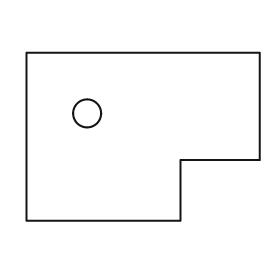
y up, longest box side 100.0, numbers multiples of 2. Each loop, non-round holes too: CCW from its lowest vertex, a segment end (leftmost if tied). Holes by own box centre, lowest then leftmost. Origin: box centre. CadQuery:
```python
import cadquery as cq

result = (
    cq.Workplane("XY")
    .moveTo(-50.0, -36.0)
    .lineTo(16.0, -36.0)
    .lineTo(16.0, -10.0)
    .lineTo(50.0, -10.0)
    .lineTo(50.0, 36.0)
    .lineTo(-50.0, 36.0)
    .close()
    .moveTo(-24.0, 10.0)
    .circle(6.0)
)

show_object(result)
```